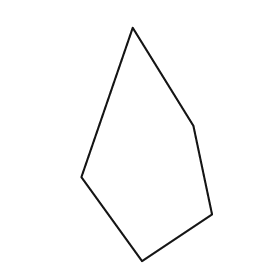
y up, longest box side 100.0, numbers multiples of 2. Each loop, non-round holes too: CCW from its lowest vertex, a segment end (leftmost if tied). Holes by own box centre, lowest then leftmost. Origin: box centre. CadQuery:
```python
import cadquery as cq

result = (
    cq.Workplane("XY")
    .moveTo(-2.0, -50.0)
    .lineTo(28.0, -30.0)
    .lineTo(20.0, 8.0)
    .lineTo(-6.0, 50.0)
    .lineTo(-28.0, -14.0)
    .close()
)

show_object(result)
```